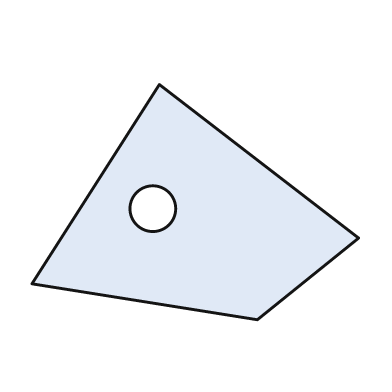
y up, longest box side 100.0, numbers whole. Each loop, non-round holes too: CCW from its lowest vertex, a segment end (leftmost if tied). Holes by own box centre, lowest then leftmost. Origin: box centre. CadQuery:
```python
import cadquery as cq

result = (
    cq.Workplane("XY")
    .moveTo(19.0, -36.0)
    .lineTo(50.0, -11.0)
    .lineTo(-11.0, 36.0)
    .lineTo(-50.0, -25.0)
    .close()
    .moveTo(-13.0, -2.0)
    .circle(7.0)
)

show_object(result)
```